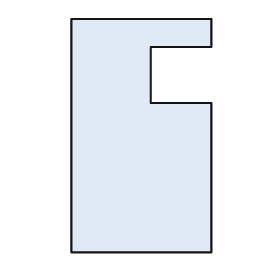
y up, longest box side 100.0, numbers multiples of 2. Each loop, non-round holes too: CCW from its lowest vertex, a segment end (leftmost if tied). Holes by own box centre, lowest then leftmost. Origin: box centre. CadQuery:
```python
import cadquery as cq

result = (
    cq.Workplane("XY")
    .moveTo(-30.0, -50.0)
    .lineTo(30.0, -50.0)
    .lineTo(30.0, 14.0)
    .lineTo(4.0, 14.0)
    .lineTo(4.0, 38.0)
    .lineTo(30.0, 38.0)
    .lineTo(30.0, 50.0)
    .lineTo(-30.0, 50.0)
    .close()
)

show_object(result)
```